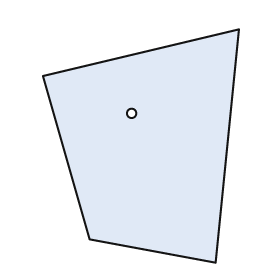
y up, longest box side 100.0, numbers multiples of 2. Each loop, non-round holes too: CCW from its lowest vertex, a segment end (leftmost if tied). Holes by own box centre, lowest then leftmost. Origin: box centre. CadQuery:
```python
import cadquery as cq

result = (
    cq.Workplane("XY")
    .moveTo(32.0, -50.0)
    .lineTo(42.0, 50.0)
    .lineTo(-42.0, 30.0)
    .lineTo(-22.0, -40.0)
    .close()
    .moveTo(-4.0, 14.0)
    .circle(2.0)
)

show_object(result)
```